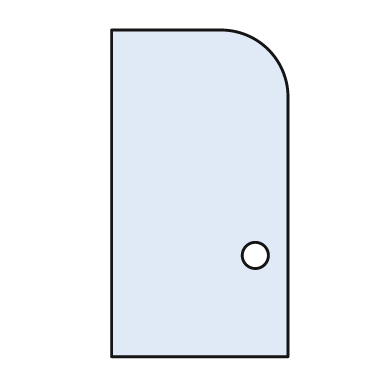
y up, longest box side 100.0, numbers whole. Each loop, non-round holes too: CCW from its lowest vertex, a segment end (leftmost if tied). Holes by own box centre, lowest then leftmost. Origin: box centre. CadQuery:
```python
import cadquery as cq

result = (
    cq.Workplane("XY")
    .moveTo(-27.0, -50.0)
    .lineTo(27.0, -50.0)
    .lineTo(27.0, 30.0)
    .threePointArc((21.0, 44.0), (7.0, 50.0))
    .lineTo(-27.0, 50.0)
    .close()
    .moveTo(17.0, -19.0)
    .circle(4.0)
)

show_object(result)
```